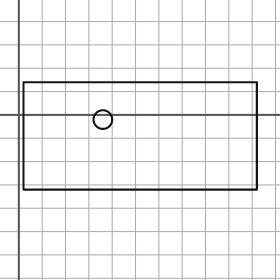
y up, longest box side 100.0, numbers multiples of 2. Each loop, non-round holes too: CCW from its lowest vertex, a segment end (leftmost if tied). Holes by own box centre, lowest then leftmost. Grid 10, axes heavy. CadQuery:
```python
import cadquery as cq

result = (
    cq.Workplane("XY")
    .moveTo(2.0, -32.0)
    .lineTo(102.0, -32.0)
    .lineTo(102.0, 14.0)
    .lineTo(2.0, 14.0)
    .close()
    .moveTo(36.0, -2.0)
    .circle(4.0)
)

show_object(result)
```